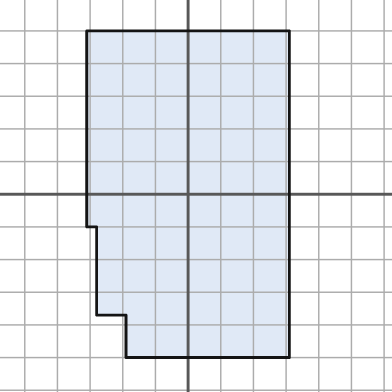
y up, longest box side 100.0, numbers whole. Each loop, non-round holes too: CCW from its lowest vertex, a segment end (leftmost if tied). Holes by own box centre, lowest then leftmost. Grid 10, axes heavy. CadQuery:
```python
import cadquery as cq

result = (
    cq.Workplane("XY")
    .moveTo(-19.0, -50.0)
    .lineTo(31.0, -50.0)
    .lineTo(31.0, 50.0)
    .lineTo(-31.0, 50.0)
    .lineTo(-31.0, -10.0)
    .lineTo(-28.0, -10.0)
    .lineTo(-28.0, -37.0)
    .lineTo(-19.0, -37.0)
    .close()
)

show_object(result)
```